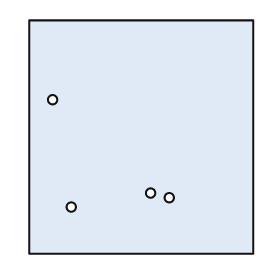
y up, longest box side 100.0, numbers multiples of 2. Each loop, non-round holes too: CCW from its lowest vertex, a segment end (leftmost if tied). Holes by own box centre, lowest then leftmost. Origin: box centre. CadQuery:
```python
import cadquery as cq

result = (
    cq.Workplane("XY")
    .moveTo(-48.0, -50.0)
    .lineTo(48.0, -50.0)
    .lineTo(48.0, 50.0)
    .lineTo(-48.0, 50.0)
    .close()
    .moveTo(-30.0, -30.0)
    .circle(2.0)
    .moveTo(12.0, -26.0)
    .circle(2.0)
    .moveTo(4.0, -24.0)
    .circle(2.0)
    .moveTo(-38.0, 16.0)
    .circle(2.0)
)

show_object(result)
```